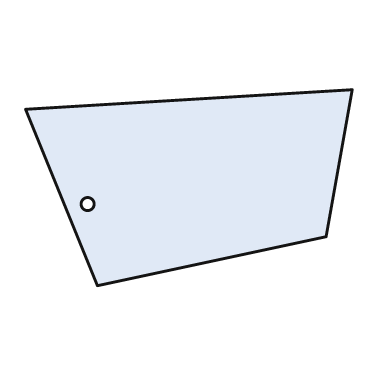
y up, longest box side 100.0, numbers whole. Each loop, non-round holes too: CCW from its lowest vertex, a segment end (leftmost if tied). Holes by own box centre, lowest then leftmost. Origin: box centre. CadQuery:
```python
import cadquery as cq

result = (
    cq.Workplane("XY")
    .moveTo(-28.0, -30.0)
    .lineTo(42.0, -15.0)
    .lineTo(50.0, 30.0)
    .lineTo(-50.0, 24.0)
    .close()
    .moveTo(-31.0, -5.0)
    .circle(2.0)
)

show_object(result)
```